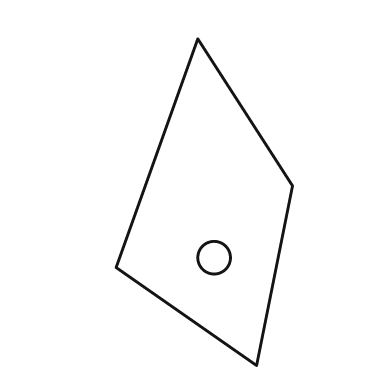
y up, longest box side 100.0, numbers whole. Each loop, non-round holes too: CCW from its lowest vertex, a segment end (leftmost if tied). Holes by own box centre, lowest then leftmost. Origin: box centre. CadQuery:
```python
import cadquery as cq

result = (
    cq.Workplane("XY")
    .moveTo(16.0, -50.0)
    .lineTo(27.0, 5.0)
    .lineTo(-2.0, 50.0)
    .lineTo(-27.0, -20.0)
    .close()
    .moveTo(3.0, -17.0)
    .circle(5.0)
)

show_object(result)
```